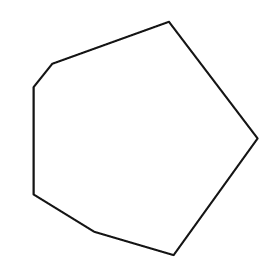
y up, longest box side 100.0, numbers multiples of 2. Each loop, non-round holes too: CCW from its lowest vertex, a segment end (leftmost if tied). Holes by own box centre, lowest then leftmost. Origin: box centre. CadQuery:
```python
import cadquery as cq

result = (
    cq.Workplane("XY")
    .moveTo(12.0, -50.0)
    .lineTo(48.0, 0.0)
    .lineTo(10.0, 50.0)
    .lineTo(-40.0, 32.0)
    .lineTo(-48.0, 22.0)
    .lineTo(-48.0, -24.0)
    .lineTo(-22.0, -40.0)
    .close()
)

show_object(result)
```